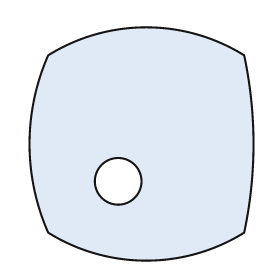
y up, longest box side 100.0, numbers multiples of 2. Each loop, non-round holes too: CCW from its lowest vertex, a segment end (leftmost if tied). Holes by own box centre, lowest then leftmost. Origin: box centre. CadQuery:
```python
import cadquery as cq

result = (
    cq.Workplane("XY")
    .moveTo(-40.0, -38.0)
    .threePointArc((2.0, -50.0), (44.0, -38.0))
    .threePointArc((48.0, 0.0), (44.0, 38.0))
    .threePointArc((2.0, 50.0), (-40.0, 38.0))
    .threePointArc((-48.0, 0.0), (-40.0, -38.0))
    .close()
    .moveTo(-10.0, -16.0)
    .circle(10.0)
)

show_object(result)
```